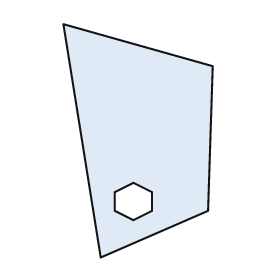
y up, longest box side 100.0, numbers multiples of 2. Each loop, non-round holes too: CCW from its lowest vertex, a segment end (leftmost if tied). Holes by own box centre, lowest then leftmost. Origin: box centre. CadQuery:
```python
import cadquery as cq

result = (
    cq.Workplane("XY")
    .moveTo(-16.0, -50.0)
    .lineTo(30.0, -30.0)
    .lineTo(32.0, 32.0)
    .lineTo(-32.0, 50.0)
    .close()
    .moveTo(-2.0, -34.0)
    .lineTo(6.0, -30.0)
    .lineTo(6.0, -22.0)
    .lineTo(-2.0, -18.0)
    .lineTo(-10.0, -22.0)
    .lineTo(-10.0, -30.0)
    .close()
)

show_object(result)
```